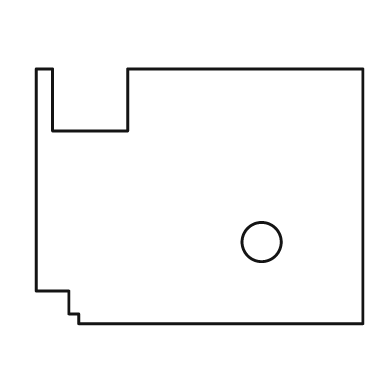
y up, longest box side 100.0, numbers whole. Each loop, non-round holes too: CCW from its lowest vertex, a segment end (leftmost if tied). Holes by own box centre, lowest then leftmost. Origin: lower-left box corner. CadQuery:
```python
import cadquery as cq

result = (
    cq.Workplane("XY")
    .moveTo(13.0, 0.0)
    .lineTo(100.0, 0.0)
    .lineTo(100.0, 78.0)
    .lineTo(28.0, 78.0)
    .lineTo(28.0, 59.0)
    .lineTo(5.0, 59.0)
    .lineTo(5.0, 78.0)
    .lineTo(0.0, 78.0)
    .lineTo(0.0, 10.0)
    .lineTo(10.0, 10.0)
    .lineTo(10.0, 3.0)
    .lineTo(13.0, 3.0)
    .close()
    .moveTo(69.0, 25.0)
    .circle(6.0)
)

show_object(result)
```